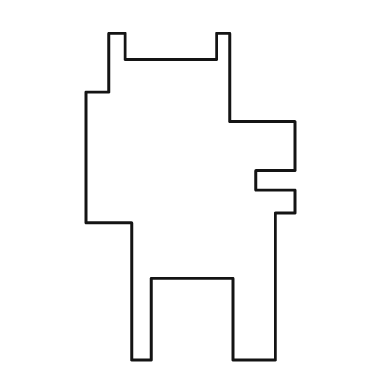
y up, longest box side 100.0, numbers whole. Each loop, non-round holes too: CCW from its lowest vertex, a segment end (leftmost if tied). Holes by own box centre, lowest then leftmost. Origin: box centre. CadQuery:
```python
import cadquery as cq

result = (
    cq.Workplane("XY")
    .moveTo(-18.0, -50.0)
    .lineTo(-12.0, -50.0)
    .lineTo(-12.0, -25.0)
    .lineTo(13.0, -25.0)
    .lineTo(13.0, -50.0)
    .lineTo(26.0, -50.0)
    .lineTo(26.0, -5.0)
    .lineTo(32.0, -5.0)
    .lineTo(32.0, 2.0)
    .lineTo(20.0, 2.0)
    .lineTo(20.0, 8.0)
    .lineTo(32.0, 8.0)
    .lineTo(32.0, 23.0)
    .lineTo(12.0, 23.0)
    .lineTo(12.0, 50.0)
    .lineTo(8.0, 50.0)
    .lineTo(8.0, 42.0)
    .lineTo(-20.0, 42.0)
    .lineTo(-20.0, 50.0)
    .lineTo(-25.0, 50.0)
    .lineTo(-25.0, 32.0)
    .lineTo(-32.0, 32.0)
    .lineTo(-32.0, -8.0)
    .lineTo(-18.0, -8.0)
    .close()
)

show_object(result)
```